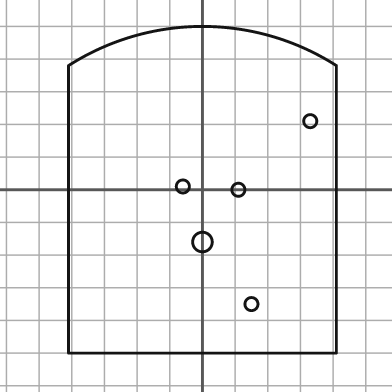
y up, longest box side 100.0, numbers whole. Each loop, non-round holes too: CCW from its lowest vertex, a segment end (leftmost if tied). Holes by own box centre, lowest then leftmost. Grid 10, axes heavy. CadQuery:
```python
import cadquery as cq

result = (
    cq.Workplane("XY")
    .moveTo(-41.0, -50.0)
    .lineTo(41.0, -50.0)
    .lineTo(41.0, 38.0)
    .threePointArc((0.0, 50.0), (-41.0, 38.0))
    .close()
    .moveTo(15.0, -35.0)
    .circle(2.0)
    .moveTo(0.0, -16.0)
    .circle(3.0)
    .moveTo(11.0, 0.0)
    .circle(2.0)
    .moveTo(-6.0, 1.0)
    .circle(2.0)
    .moveTo(33.0, 21.0)
    .circle(2.0)
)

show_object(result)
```